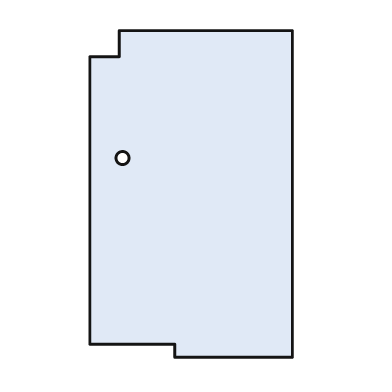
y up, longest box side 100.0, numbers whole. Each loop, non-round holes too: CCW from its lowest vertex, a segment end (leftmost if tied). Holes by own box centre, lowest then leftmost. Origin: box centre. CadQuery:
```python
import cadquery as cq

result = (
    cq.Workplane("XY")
    .moveTo(-5.0, -50.0)
    .lineTo(31.0, -50.0)
    .lineTo(31.0, 50.0)
    .lineTo(-22.0, 50.0)
    .lineTo(-22.0, 42.0)
    .lineTo(-31.0, 42.0)
    .lineTo(-31.0, -46.0)
    .lineTo(-5.0, -46.0)
    .close()
    .moveTo(-21.0, 11.0)
    .circle(2.0)
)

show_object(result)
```